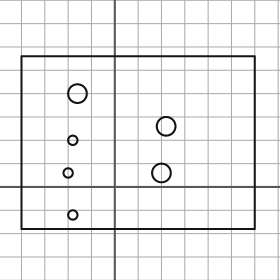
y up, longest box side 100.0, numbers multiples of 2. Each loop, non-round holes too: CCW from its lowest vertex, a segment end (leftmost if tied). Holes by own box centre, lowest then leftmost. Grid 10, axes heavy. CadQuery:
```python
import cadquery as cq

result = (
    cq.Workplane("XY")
    .moveTo(-40.0, -18.0)
    .lineTo(60.0, -18.0)
    .lineTo(60.0, 56.0)
    .lineTo(-40.0, 56.0)
    .close()
    .moveTo(-18.0, -12.0)
    .circle(2.0)
    .moveTo(-20.0, 6.0)
    .circle(2.0)
    .moveTo(20.0, 6.0)
    .circle(4.0)
    .moveTo(-18.0, 20.0)
    .circle(2.0)
    .moveTo(22.0, 26.0)
    .circle(4.0)
    .moveTo(-16.0, 40.0)
    .circle(4.0)
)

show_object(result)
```